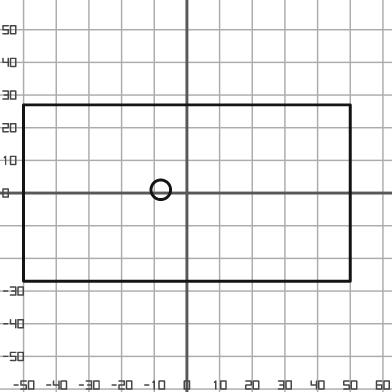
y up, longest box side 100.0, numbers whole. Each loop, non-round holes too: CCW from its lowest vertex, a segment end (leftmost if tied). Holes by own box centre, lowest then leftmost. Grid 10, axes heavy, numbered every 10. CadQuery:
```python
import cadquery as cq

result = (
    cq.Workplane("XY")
    .moveTo(-50.0, -27.0)
    .lineTo(50.0, -27.0)
    .lineTo(50.0, 27.0)
    .lineTo(-50.0, 27.0)
    .close()
    .moveTo(-8.0, 1.0)
    .circle(3.0)
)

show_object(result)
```